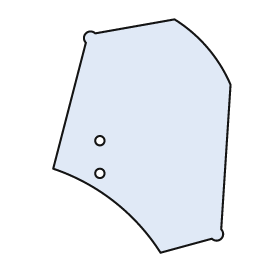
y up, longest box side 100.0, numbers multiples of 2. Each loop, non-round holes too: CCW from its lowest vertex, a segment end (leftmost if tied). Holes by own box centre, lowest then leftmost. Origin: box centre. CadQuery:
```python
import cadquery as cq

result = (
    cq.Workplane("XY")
    .moveTo(8.0, -50.0)
    .lineTo(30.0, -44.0)
    .threePointArc((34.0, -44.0), (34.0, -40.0))
    .lineTo(38.0, 22.0)
    .threePointArc((28.0, 38.0), (14.0, 50.0))
    .lineTo(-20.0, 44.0)
    .threePointArc((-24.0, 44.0), (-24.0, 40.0))
    .lineTo(-38.0, -14.0)
    .threePointArc((-12.0, -28.0), (8.0, -50.0))
    .close()
    .moveTo(-18.0, -16.0)
    .circle(2.0)
    .moveTo(-18.0, -2.0)
    .circle(2.0)
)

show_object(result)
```